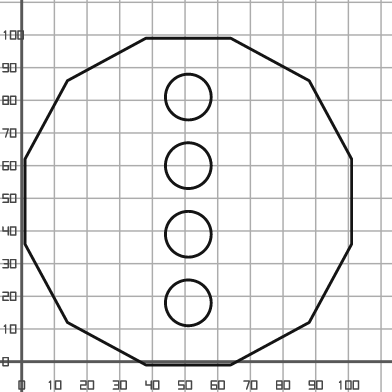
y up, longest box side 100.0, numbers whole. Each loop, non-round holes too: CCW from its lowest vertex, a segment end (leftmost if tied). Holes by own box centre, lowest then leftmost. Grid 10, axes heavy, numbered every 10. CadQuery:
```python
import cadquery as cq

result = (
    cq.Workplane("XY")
    .moveTo(38.0, -1.0)
    .lineTo(64.0, -1.0)
    .lineTo(88.0, 12.0)
    .lineTo(101.0, 36.0)
    .lineTo(101.0, 62.0)
    .lineTo(88.0, 86.0)
    .lineTo(64.0, 99.0)
    .lineTo(38.0, 99.0)
    .lineTo(14.0, 86.0)
    .lineTo(1.0, 62.0)
    .lineTo(1.0, 36.0)
    .lineTo(14.0, 12.0)
    .close()
    .moveTo(51.0, 18.0)
    .circle(7.0)
    .moveTo(51.0, 39.0)
    .circle(7.0)
    .moveTo(51.0, 60.0)
    .circle(7.0)
    .moveTo(51.0, 81.0)
    .circle(7.0)
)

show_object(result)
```